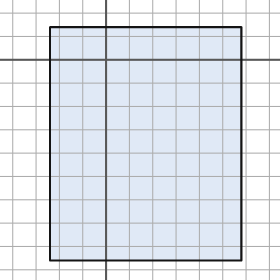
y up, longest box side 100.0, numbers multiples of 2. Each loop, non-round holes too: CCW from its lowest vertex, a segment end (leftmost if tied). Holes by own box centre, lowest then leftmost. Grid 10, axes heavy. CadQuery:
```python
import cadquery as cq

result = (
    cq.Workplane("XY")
    .moveTo(-24.0, -86.0)
    .lineTo(58.0, -86.0)
    .lineTo(58.0, 14.0)
    .lineTo(-24.0, 14.0)
    .close()
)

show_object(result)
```